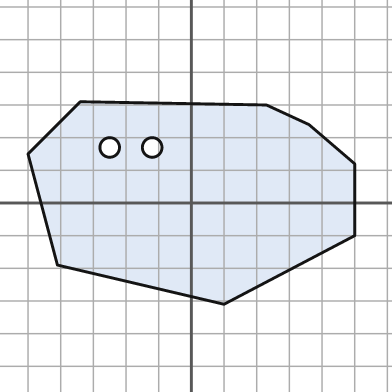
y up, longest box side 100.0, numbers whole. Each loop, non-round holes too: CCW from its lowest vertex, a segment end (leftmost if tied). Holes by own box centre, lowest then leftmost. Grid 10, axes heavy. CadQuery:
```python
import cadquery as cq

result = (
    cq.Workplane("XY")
    .moveTo(10.0, -31.0)
    .lineTo(50.0, -10.0)
    .lineTo(50.0, 12.0)
    .lineTo(36.0, 24.0)
    .lineTo(23.0, 30.0)
    .lineTo(-34.0, 31.0)
    .lineTo(-50.0, 15.0)
    .lineTo(-41.0, -19.0)
    .close()
    .moveTo(-25.0, 17.0)
    .circle(3.0)
    .moveTo(-12.0, 17.0)
    .circle(3.0)
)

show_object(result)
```